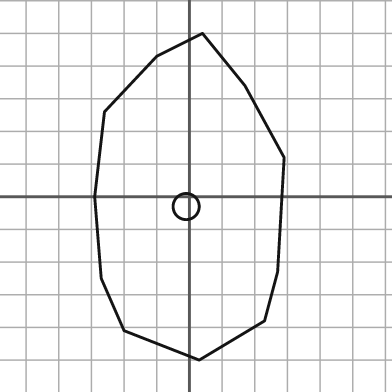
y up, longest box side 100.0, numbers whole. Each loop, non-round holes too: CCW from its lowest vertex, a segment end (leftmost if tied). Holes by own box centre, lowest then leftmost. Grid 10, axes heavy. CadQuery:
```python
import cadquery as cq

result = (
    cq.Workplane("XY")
    .moveTo(3.0, -50.0)
    .lineTo(23.0, -38.0)
    .lineTo(27.0, -23.0)
    .lineTo(29.0, 12.0)
    .lineTo(17.0, 34.0)
    .lineTo(4.0, 50.0)
    .lineTo(-10.0, 43.0)
    .lineTo(-26.0, 26.0)
    .lineTo(-29.0, 0.0)
    .lineTo(-27.0, -25.0)
    .lineTo(-20.0, -41.0)
    .close()
    .moveTo(-1.0, -3.0)
    .circle(4.0)
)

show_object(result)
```